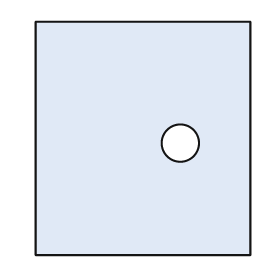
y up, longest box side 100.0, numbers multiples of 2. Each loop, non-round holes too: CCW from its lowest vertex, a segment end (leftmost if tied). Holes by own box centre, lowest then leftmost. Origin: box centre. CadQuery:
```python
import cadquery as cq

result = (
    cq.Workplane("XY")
    .moveTo(-46.0, -50.0)
    .lineTo(46.0, -50.0)
    .lineTo(46.0, 50.0)
    .lineTo(-46.0, 50.0)
    .close()
    .moveTo(16.0, -2.0)
    .circle(8.0)
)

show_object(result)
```